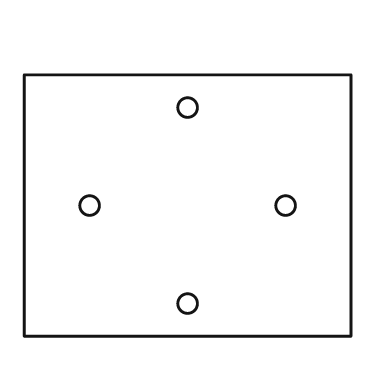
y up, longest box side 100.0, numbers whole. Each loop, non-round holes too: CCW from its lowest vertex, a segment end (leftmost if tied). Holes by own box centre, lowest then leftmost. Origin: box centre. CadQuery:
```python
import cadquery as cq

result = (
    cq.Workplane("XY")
    .moveTo(-50.0, -40.0)
    .lineTo(50.0, -40.0)
    .lineTo(50.0, 40.0)
    .lineTo(-50.0, 40.0)
    .close()
    .moveTo(0.0, -30.0)
    .circle(3.0)
    .moveTo(-30.0, 0.0)
    .circle(3.0)
    .moveTo(30.0, 0.0)
    .circle(3.0)
    .moveTo(0.0, 30.0)
    .circle(3.0)
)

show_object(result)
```